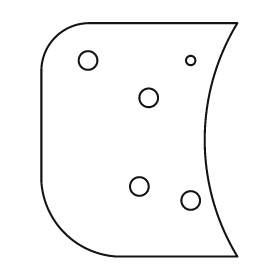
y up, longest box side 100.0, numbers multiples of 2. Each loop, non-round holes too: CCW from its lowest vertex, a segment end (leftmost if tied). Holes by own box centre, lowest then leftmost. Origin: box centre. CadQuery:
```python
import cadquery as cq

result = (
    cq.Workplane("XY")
    .moveTo(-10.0, -50.0)
    .lineTo(42.0, -50.0)
    .threePointArc((28.0, 0.0), (42.0, 50.0))
    .lineTo(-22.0, 50.0)
    .threePointArc((-36.0, 44.0), (-42.0, 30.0))
    .lineTo(-42.0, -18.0)
    .threePointArc((-32.0, -40.0), (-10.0, -50.0))
    .close()
    .moveTo(22.0, -26.0)
    .circle(4.0)
    .moveTo(0.0, -20.0)
    .circle(4.0)
    .moveTo(4.0, 18.0)
    .circle(4.0)
    .moveTo(-22.0, 34.0)
    .circle(4.0)
    .moveTo(22.0, 34.0)
    .circle(2.0)
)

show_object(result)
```